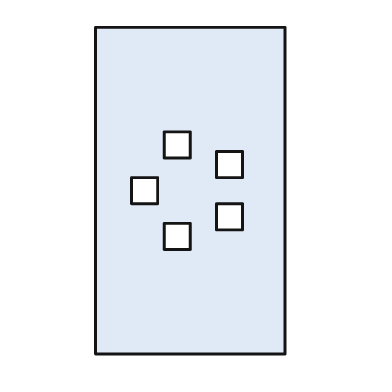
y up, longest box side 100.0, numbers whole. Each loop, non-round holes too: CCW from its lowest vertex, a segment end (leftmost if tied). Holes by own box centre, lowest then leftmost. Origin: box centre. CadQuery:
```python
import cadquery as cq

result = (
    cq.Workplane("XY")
    .moveTo(-29.0, -50.0)
    .lineTo(29.0, -50.0)
    .lineTo(29.0, 50.0)
    .lineTo(-29.0, 50.0)
    .close()
    .moveTo(-8.0, -18.0)
    .lineTo(0.0, -18.0)
    .lineTo(0.0, -10.0)
    .lineTo(-8.0, -10.0)
    .close()
    .moveTo(8.0, -12.0)
    .lineTo(16.0, -12.0)
    .lineTo(16.0, -4.0)
    .lineTo(8.0, -4.0)
    .close()
    .moveTo(-18.0, -4.0)
    .lineTo(-10.0, -4.0)
    .lineTo(-10.0, 4.0)
    .lineTo(-18.0, 4.0)
    .close()
    .moveTo(8.0, 4.0)
    .lineTo(16.0, 4.0)
    .lineTo(16.0, 12.0)
    .lineTo(8.0, 12.0)
    .close()
    .moveTo(-8.0, 10.0)
    .lineTo(0.0, 10.0)
    .lineTo(0.0, 18.0)
    .lineTo(-8.0, 18.0)
    .close()
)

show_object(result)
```